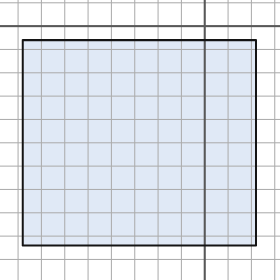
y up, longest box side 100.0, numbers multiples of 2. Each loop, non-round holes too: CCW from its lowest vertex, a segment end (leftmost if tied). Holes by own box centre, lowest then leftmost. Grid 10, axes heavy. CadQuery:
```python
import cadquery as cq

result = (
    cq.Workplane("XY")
    .moveTo(-78.0, -94.0)
    .lineTo(22.0, -94.0)
    .lineTo(22.0, -6.0)
    .lineTo(-78.0, -6.0)
    .close()
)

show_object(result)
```